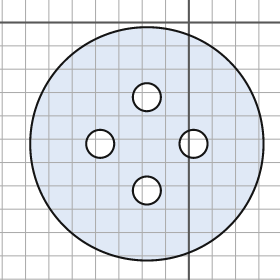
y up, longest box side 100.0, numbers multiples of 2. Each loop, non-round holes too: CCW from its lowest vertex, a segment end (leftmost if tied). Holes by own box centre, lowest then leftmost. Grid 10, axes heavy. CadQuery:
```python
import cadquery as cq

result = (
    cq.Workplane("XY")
    .moveTo(-18.0, -52.0)
    .circle(50.0)
    .moveTo(-18.0, -72.0)
    .circle(6.0)
    .moveTo(-38.0, -52.0)
    .circle(6.0)
    .moveTo(2.0, -52.0)
    .circle(6.0)
    .moveTo(-18.0, -32.0)
    .circle(6.0)
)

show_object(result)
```